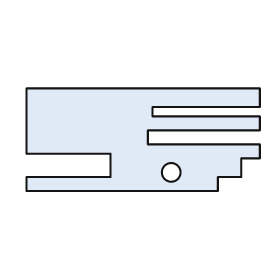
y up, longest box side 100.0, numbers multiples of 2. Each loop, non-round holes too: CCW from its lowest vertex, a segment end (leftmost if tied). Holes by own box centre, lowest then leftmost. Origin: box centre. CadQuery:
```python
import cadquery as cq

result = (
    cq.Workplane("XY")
    .moveTo(-50.0, -22.0)
    .lineTo(32.0, -22.0)
    .lineTo(32.0, -16.0)
    .lineTo(42.0, -16.0)
    .lineTo(42.0, -8.0)
    .lineTo(50.0, -8.0)
    .lineTo(50.0, -2.0)
    .lineTo(2.0, -2.0)
    .lineTo(2.0, 4.0)
    .lineTo(50.0, 4.0)
    .lineTo(50.0, 10.0)
    .lineTo(4.0, 10.0)
    .lineTo(4.0, 14.0)
    .lineTo(50.0, 14.0)
    .lineTo(50.0, 22.0)
    .lineTo(-50.0, 22.0)
    .lineTo(-50.0, -6.0)
    .lineTo(-14.0, -6.0)
    .lineTo(-14.0, -16.0)
    .lineTo(-50.0, -16.0)
    .close()
    .moveTo(12.0, -14.0)
    .circle(4.0)
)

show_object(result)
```